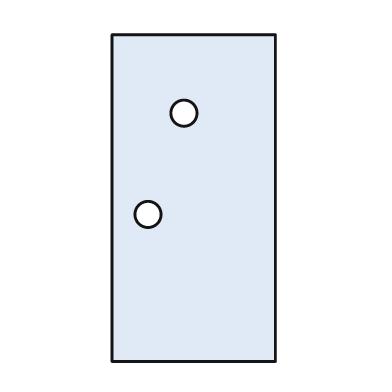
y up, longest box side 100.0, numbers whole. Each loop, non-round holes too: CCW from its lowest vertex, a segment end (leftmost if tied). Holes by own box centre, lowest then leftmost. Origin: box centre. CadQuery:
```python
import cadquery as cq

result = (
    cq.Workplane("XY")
    .moveTo(-25.0, -50.0)
    .lineTo(25.0, -50.0)
    .lineTo(25.0, 50.0)
    .lineTo(-25.0, 50.0)
    .close()
    .moveTo(-14.0, -5.0)
    .circle(4.0)
    .moveTo(-3.0, 26.0)
    .circle(4.0)
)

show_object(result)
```